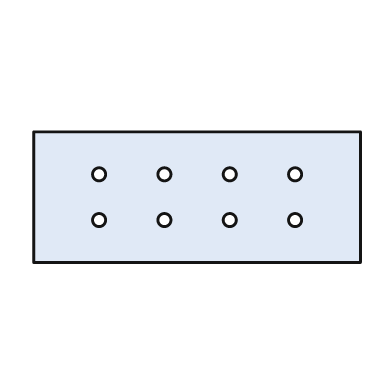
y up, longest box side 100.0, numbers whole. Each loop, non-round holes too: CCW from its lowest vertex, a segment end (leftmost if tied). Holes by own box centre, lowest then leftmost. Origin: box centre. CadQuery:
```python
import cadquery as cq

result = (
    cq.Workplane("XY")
    .moveTo(-50.0, -20.0)
    .lineTo(50.0, -20.0)
    .lineTo(50.0, 20.0)
    .lineTo(-50.0, 20.0)
    .close()
    .moveTo(-30.0, -7.0)
    .circle(2.0)
    .moveTo(-10.0, -7.0)
    .circle(2.0)
    .moveTo(10.0, -7.0)
    .circle(2.0)
    .moveTo(30.0, -7.0)
    .circle(2.0)
    .moveTo(-30.0, 7.0)
    .circle(2.0)
    .moveTo(-10.0, 7.0)
    .circle(2.0)
    .moveTo(10.0, 7.0)
    .circle(2.0)
    .moveTo(30.0, 7.0)
    .circle(2.0)
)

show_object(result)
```